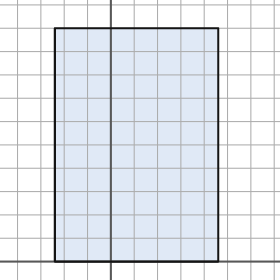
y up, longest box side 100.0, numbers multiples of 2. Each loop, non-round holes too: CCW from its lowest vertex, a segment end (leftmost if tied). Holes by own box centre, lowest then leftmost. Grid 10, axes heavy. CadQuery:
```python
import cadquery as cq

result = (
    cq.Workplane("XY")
    .moveTo(-24.0, 0.0)
    .lineTo(46.0, 0.0)
    .lineTo(46.0, 100.0)
    .lineTo(-24.0, 100.0)
    .close()
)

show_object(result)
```